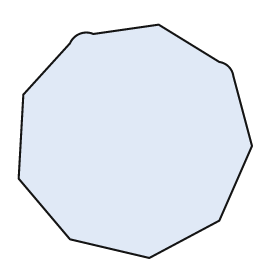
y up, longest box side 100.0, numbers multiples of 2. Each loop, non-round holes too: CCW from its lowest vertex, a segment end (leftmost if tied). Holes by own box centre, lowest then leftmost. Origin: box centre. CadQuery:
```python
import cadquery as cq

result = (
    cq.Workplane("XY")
    .moveTo(6.0, -50.0)
    .lineTo(36.0, -34.0)
    .lineTo(50.0, -2.0)
    .lineTo(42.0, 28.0)
    .threePointArc((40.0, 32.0), (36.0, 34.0))
    .lineTo(10.0, 50.0)
    .lineTo(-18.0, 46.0)
    .threePointArc((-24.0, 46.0), (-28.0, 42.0))
    .lineTo(-48.0, 20.0)
    .lineTo(-50.0, -16.0)
    .lineTo(-28.0, -42.0)
    .close()
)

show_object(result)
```